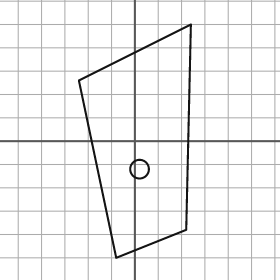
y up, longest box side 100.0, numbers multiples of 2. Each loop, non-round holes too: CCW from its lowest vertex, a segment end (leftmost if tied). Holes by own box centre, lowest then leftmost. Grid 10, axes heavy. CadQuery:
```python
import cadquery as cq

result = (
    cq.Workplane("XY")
    .moveTo(-8.0, -50.0)
    .lineTo(22.0, -38.0)
    .lineTo(24.0, 50.0)
    .lineTo(-24.0, 26.0)
    .close()
    .moveTo(2.0, -12.0)
    .circle(4.0)
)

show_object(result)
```